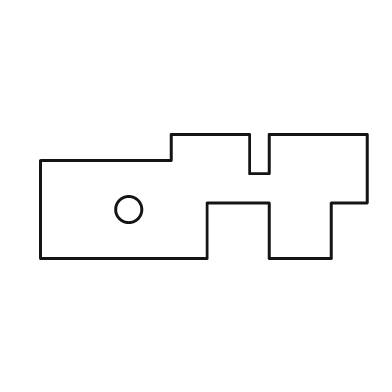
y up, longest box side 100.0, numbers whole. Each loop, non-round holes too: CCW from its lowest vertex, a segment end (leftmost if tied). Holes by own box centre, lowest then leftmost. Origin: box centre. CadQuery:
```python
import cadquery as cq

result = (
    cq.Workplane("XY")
    .moveTo(-50.0, -19.0)
    .lineTo(1.0, -19.0)
    .lineTo(1.0, -2.0)
    .lineTo(20.0, -2.0)
    .lineTo(20.0, -19.0)
    .lineTo(39.0, -19.0)
    .lineTo(39.0, -2.0)
    .lineTo(50.0, -2.0)
    .lineTo(50.0, 19.0)
    .lineTo(20.0, 19.0)
    .lineTo(20.0, 7.0)
    .lineTo(14.0, 7.0)
    .lineTo(14.0, 19.0)
    .lineTo(-10.0, 19.0)
    .lineTo(-10.0, 11.0)
    .lineTo(-50.0, 11.0)
    .close()
    .moveTo(-23.0, -4.0)
    .circle(4.0)
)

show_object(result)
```